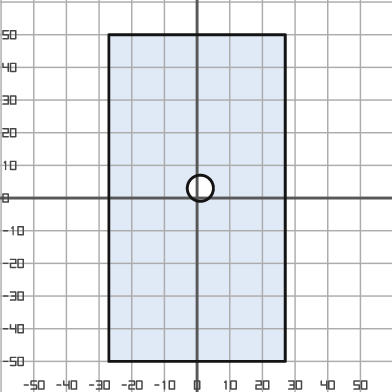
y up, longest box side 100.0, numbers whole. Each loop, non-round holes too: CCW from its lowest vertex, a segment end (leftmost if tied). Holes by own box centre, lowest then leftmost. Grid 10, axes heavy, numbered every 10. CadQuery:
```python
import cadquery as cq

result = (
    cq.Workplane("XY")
    .moveTo(-27.0, -50.0)
    .lineTo(27.0, -50.0)
    .lineTo(27.0, 50.0)
    .lineTo(-27.0, 50.0)
    .close()
    .moveTo(1.0, 3.0)
    .circle(4.0)
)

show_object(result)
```